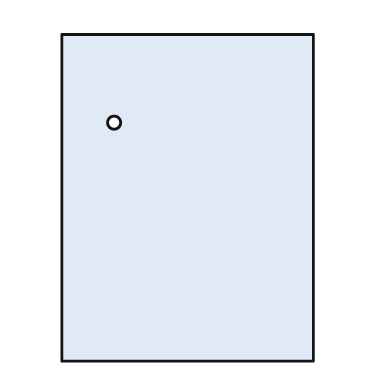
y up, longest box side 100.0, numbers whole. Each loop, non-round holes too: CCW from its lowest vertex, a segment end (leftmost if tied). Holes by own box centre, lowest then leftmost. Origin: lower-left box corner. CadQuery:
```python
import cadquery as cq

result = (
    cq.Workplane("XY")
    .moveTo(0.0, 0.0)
    .lineTo(77.0, 0.0)
    .lineTo(77.0, 100.0)
    .lineTo(0.0, 100.0)
    .close()
    .moveTo(16.0, 73.0)
    .circle(2.0)
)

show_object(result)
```